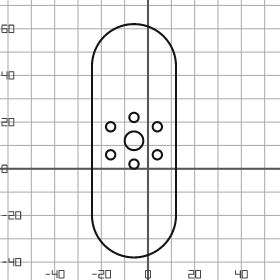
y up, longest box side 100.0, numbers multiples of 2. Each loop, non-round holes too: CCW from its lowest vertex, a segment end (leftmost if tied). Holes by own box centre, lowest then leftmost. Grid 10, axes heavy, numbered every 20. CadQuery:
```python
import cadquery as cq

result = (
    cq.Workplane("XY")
    .moveTo(-24.0, -20.0)
    .threePointArc((-6.0, -38.0), (12.0, -20.0))
    .lineTo(12.0, 44.0)
    .threePointArc((-6.0, 62.0), (-24.0, 44.0))
    .close()
    .moveTo(-6.0, 2.0)
    .circle(2.0)
    .moveTo(-16.0, 6.0)
    .circle(2.0)
    .moveTo(4.0, 6.0)
    .circle(2.0)
    .moveTo(-6.0, 12.0)
    .circle(4.0)
    .moveTo(-16.0, 18.0)
    .circle(2.0)
    .moveTo(4.0, 18.0)
    .circle(2.0)
    .moveTo(-6.0, 22.0)
    .circle(2.0)
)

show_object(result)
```